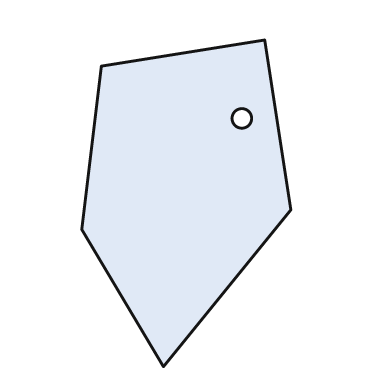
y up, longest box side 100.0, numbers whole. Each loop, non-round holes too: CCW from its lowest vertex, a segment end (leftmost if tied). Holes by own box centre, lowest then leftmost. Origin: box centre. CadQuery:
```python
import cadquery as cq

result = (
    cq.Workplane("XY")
    .moveTo(-7.0, -50.0)
    .lineTo(32.0, -2.0)
    .lineTo(24.0, 50.0)
    .lineTo(-26.0, 42.0)
    .lineTo(-32.0, -8.0)
    .close()
    .moveTo(17.0, 26.0)
    .circle(3.0)
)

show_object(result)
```